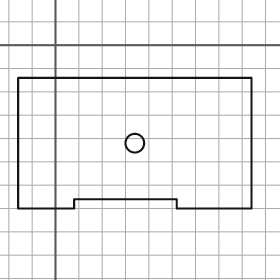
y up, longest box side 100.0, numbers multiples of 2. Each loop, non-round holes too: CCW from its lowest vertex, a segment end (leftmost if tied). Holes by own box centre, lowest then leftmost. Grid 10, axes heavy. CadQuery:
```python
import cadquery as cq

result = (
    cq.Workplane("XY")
    .moveTo(-16.0, -70.0)
    .lineTo(8.0, -70.0)
    .lineTo(8.0, -66.0)
    .lineTo(52.0, -66.0)
    .lineTo(52.0, -70.0)
    .lineTo(84.0, -70.0)
    .lineTo(84.0, -14.0)
    .lineTo(-16.0, -14.0)
    .close()
    .moveTo(34.0, -42.0)
    .circle(4.0)
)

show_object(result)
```